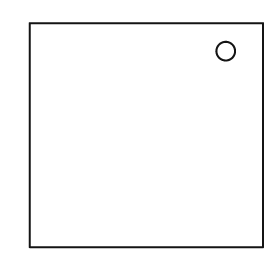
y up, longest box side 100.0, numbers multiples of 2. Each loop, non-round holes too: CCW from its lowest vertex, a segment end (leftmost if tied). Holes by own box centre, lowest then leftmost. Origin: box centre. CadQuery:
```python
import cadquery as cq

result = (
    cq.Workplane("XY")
    .moveTo(-50.0, -48.0)
    .lineTo(50.0, -48.0)
    .lineTo(50.0, 48.0)
    .lineTo(-50.0, 48.0)
    .close()
    .moveTo(34.0, 36.0)
    .circle(4.0)
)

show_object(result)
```